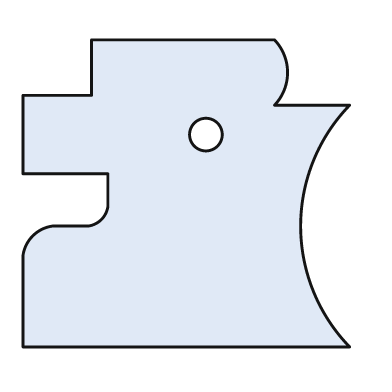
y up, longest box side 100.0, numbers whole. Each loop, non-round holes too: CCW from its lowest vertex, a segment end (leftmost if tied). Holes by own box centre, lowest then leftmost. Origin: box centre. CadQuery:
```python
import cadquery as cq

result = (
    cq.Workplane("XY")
    .moveTo(-50.0, -47.0)
    .lineTo(50.0, -47.0)
    .threePointArc((35.0, -10.0), (50.0, 27.0))
    .lineTo(27.0, 27.0)
    .threePointArc((31.0, 37.0), (27.0, 47.0))
    .lineTo(-29.0, 47.0)
    .lineTo(-29.0, 30.0)
    .lineTo(-50.0, 30.0)
    .lineTo(-50.0, 6.0)
    .lineTo(-24.0, 6.0)
    .lineTo(-24.0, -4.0)
    .threePointArc((-26.0, -8.0), (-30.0, -10.0))
    .lineTo(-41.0, -10.0)
    .threePointArc((-47.0, -13.0), (-50.0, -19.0))
    .close()
    .moveTo(6.0, 18.0)
    .circle(5.0)
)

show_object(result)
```